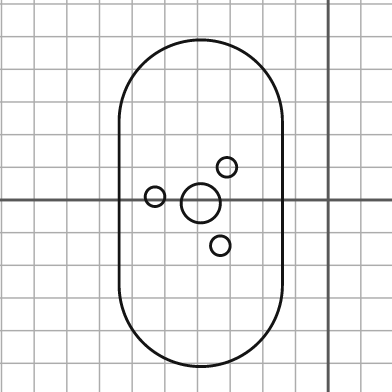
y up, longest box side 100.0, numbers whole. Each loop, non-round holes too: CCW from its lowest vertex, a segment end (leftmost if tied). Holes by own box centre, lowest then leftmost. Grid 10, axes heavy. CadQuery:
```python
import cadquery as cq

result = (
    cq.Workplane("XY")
    .moveTo(-64.0, -26.0)
    .threePointArc((-39.0, -51.0), (-14.0, -26.0))
    .lineTo(-14.0, 24.0)
    .threePointArc((-39.0, 49.0), (-64.0, 24.0))
    .close()
    .moveTo(-33.0, -14.0)
    .circle(3.0)
    .moveTo(-39.0, -1.0)
    .circle(6.0)
    .moveTo(-53.0, 1.0)
    .circle(3.0)
    .moveTo(-31.0, 10.0)
    .circle(3.0)
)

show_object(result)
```